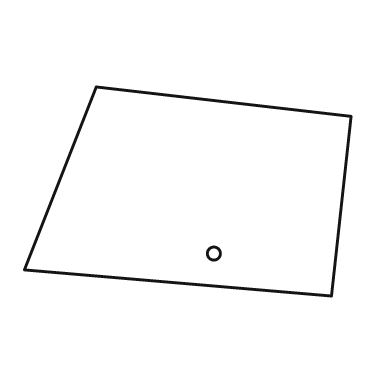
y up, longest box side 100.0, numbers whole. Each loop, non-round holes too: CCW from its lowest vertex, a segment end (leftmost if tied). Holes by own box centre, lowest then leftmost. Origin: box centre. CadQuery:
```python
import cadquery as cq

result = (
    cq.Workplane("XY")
    .moveTo(44.0, -32.0)
    .lineTo(50.0, 23.0)
    .lineTo(-28.0, 32.0)
    .lineTo(-50.0, -24.0)
    .close()
    .moveTo(8.0, -19.0)
    .circle(2.0)
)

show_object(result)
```